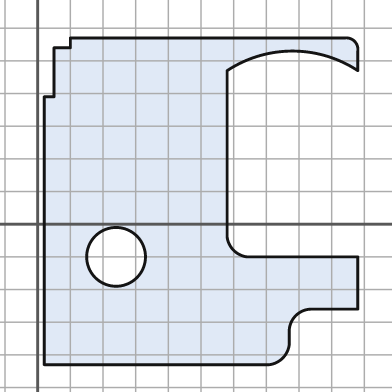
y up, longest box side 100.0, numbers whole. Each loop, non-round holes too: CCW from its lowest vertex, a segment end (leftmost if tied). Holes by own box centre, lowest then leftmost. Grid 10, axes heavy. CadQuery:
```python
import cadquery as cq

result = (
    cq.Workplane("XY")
    .moveTo(2.0, -43.0)
    .lineTo(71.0, -43.0)
    .threePointArc((75.0, -41.0), (77.0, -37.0))
    .lineTo(77.0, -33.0)
    .threePointArc((79.0, -28.0), (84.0, -26.0))
    .lineTo(98.0, -26.0)
    .lineTo(98.0, -10.0)
    .lineTo(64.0, -10.0)
    .threePointArc((60.0, -8.0), (58.0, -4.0))
    .lineTo(58.0, 47.0)
    .threePointArc((78.0, 53.0), (98.0, 47.0))
    .lineTo(98.0, 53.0)
    .threePointArc((97.0, 56.0), (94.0, 57.0))
    .lineTo(10.0, 57.0)
    .lineTo(10.0, 54.0)
    .lineTo(5.0, 54.0)
    .lineTo(5.0, 39.0)
    .lineTo(2.0, 39.0)
    .close()
    .moveTo(24.0, -10.0)
    .circle(9.0)
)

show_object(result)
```